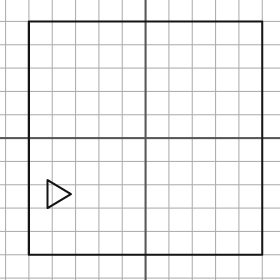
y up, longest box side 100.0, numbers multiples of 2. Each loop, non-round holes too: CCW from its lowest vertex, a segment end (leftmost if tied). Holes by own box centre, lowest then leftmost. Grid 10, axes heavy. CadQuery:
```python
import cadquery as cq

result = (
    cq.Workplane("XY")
    .moveTo(-50.0, -50.0)
    .lineTo(50.0, -50.0)
    .lineTo(50.0, 50.0)
    .lineTo(-50.0, 50.0)
    .close()
    .moveTo(-42.0, -30.0)
    .lineTo(-32.0, -24.0)
    .lineTo(-42.0, -18.0)
    .close()
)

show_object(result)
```